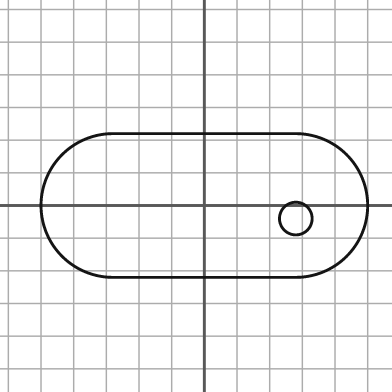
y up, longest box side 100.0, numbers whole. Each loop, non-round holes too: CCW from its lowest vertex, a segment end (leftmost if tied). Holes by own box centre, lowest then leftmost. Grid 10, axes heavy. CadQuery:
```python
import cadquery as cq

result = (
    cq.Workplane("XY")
    .moveTo(-28.0, -22.0)
    .lineTo(28.0, -22.0)
    .threePointArc((50.0, 0.0), (28.0, 22.0))
    .lineTo(-28.0, 22.0)
    .threePointArc((-50.0, 0.0), (-28.0, -22.0))
    .close()
    .moveTo(28.0, -4.0)
    .circle(5.0)
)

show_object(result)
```